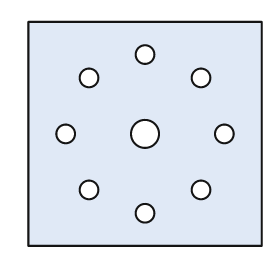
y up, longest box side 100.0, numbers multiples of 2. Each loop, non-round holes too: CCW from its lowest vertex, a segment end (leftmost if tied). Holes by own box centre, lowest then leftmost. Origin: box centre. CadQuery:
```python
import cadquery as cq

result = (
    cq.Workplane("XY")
    .moveTo(-50.0, -48.0)
    .lineTo(50.0, -48.0)
    .lineTo(50.0, 48.0)
    .lineTo(-50.0, 48.0)
    .close()
    .moveTo(0.0, -34.0)
    .circle(4.0)
    .moveTo(-24.0, -24.0)
    .circle(4.0)
    .moveTo(24.0, -24.0)
    .circle(4.0)
    .moveTo(-34.0, 0.0)
    .circle(4.0)
    .moveTo(0.0, 0.0)
    .circle(6.0)
    .moveTo(34.0, 0.0)
    .circle(4.0)
    .moveTo(-24.0, 24.0)
    .circle(4.0)
    .moveTo(24.0, 24.0)
    .circle(4.0)
    .moveTo(0.0, 34.0)
    .circle(4.0)
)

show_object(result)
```